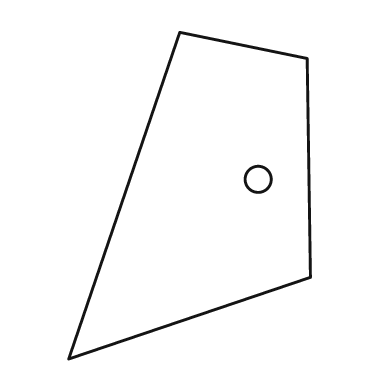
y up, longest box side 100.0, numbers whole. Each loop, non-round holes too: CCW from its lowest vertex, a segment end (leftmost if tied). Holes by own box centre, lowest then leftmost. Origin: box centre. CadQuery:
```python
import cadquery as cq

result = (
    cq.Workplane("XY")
    .moveTo(-37.0, -50.0)
    .lineTo(37.0, -25.0)
    .lineTo(36.0, 42.0)
    .lineTo(-3.0, 50.0)
    .close()
    .moveTo(21.0, 5.0)
    .circle(4.0)
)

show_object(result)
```